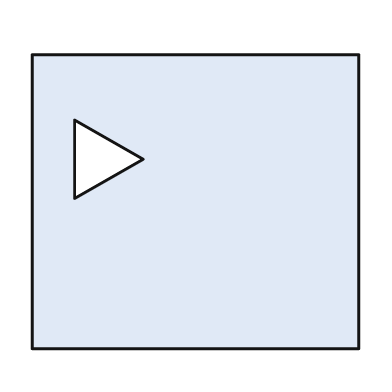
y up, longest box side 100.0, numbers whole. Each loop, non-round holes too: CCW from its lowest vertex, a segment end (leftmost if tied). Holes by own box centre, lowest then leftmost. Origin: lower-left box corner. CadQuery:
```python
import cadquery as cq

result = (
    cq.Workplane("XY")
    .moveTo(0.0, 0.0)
    .lineTo(100.0, 0.0)
    .lineTo(100.0, 90.0)
    .lineTo(0.0, 90.0)
    .close()
    .moveTo(13.0, 46.0)
    .lineTo(34.0, 58.0)
    .lineTo(13.0, 70.0)
    .close()
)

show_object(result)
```